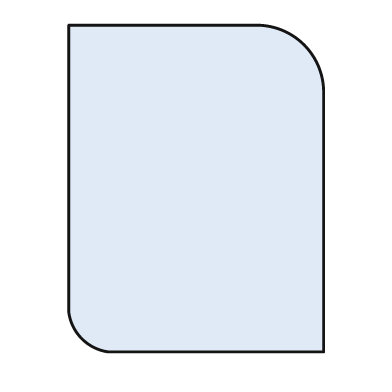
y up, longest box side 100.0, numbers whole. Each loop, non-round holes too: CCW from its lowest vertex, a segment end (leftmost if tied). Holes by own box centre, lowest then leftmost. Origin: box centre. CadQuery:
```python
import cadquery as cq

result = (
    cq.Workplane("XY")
    .moveTo(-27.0, -50.0)
    .lineTo(39.0, -50.0)
    .lineTo(39.0, 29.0)
    .threePointArc((33.0, 44.0), (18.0, 50.0))
    .lineTo(-39.0, 50.0)
    .lineTo(-39.0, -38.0)
    .threePointArc((-35.0, -46.0), (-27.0, -50.0))
    .close()
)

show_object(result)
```